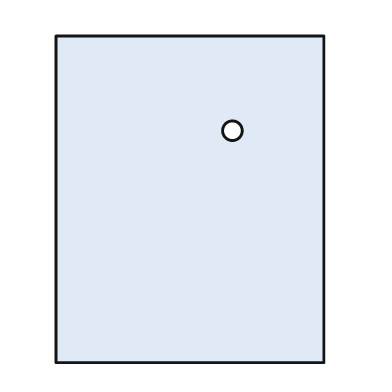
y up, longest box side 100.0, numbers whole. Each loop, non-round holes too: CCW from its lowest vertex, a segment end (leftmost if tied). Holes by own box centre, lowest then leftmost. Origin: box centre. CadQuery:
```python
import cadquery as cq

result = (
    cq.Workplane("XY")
    .moveTo(-41.0, -50.0)
    .lineTo(41.0, -50.0)
    .lineTo(41.0, 50.0)
    .lineTo(-41.0, 50.0)
    .close()
    .moveTo(13.0, 21.0)
    .circle(3.0)
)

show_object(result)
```